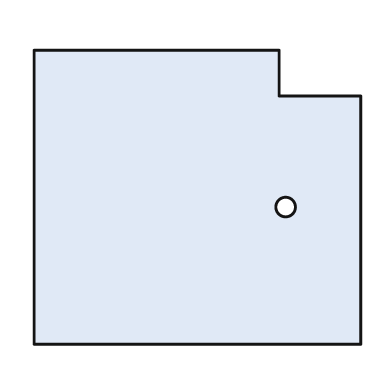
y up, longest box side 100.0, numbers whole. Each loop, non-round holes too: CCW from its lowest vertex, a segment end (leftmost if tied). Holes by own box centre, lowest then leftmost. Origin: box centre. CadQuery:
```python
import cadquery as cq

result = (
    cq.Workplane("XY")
    .moveTo(-50.0, -45.0)
    .lineTo(50.0, -45.0)
    .lineTo(50.0, 31.0)
    .lineTo(25.0, 31.0)
    .lineTo(25.0, 45.0)
    .lineTo(-50.0, 45.0)
    .close()
    .moveTo(27.0, -3.0)
    .circle(3.0)
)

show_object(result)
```